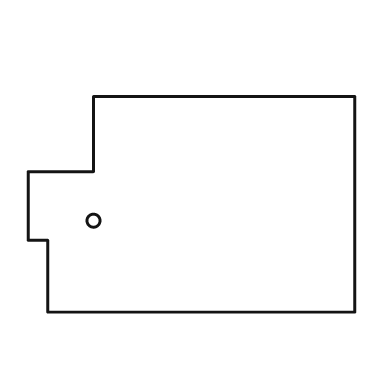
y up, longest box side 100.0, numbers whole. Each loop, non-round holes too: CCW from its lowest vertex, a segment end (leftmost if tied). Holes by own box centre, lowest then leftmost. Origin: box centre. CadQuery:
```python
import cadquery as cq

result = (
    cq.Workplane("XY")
    .moveTo(-44.0, -33.0)
    .lineTo(50.0, -33.0)
    .lineTo(50.0, 33.0)
    .lineTo(-30.0, 33.0)
    .lineTo(-30.0, 10.0)
    .lineTo(-50.0, 10.0)
    .lineTo(-50.0, -11.0)
    .lineTo(-44.0, -11.0)
    .close()
    .moveTo(-30.0, -5.0)
    .circle(2.0)
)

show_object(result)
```